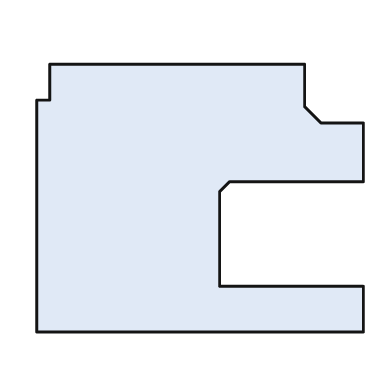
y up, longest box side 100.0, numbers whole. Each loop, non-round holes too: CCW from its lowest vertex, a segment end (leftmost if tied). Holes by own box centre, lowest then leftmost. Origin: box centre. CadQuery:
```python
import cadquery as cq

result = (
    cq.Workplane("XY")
    .moveTo(-50.0, -41.0)
    .lineTo(50.0, -41.0)
    .lineTo(50.0, -27.0)
    .lineTo(6.0, -27.0)
    .lineTo(6.0, 2.0)
    .lineTo(9.0, 5.0)
    .lineTo(50.0, 5.0)
    .lineTo(50.0, 23.0)
    .lineTo(37.0, 23.0)
    .lineTo(32.0, 28.0)
    .lineTo(32.0, 41.0)
    .lineTo(-46.0, 41.0)
    .lineTo(-46.0, 30.0)
    .lineTo(-50.0, 30.0)
    .close()
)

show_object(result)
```